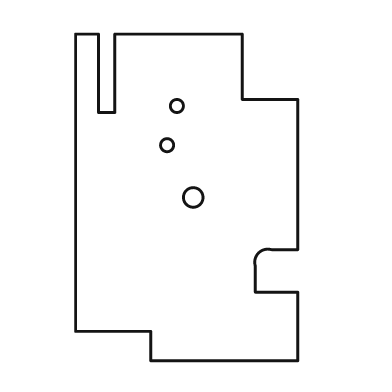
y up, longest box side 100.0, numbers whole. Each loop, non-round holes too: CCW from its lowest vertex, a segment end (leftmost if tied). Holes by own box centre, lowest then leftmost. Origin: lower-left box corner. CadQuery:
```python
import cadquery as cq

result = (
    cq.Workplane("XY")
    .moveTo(23.0, 0.0)
    .lineTo(68.0, 0.0)
    .lineTo(68.0, 21.0)
    .lineTo(55.0, 21.0)
    .lineTo(55.0, 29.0)
    .threePointArc((56.0, 33.0), (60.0, 34.0))
    .lineTo(68.0, 34.0)
    .lineTo(68.0, 80.0)
    .lineTo(51.0, 80.0)
    .lineTo(51.0, 100.0)
    .lineTo(12.0, 100.0)
    .lineTo(12.0, 76.0)
    .lineTo(7.0, 76.0)
    .lineTo(7.0, 100.0)
    .lineTo(0.0, 100.0)
    .lineTo(0.0, 9.0)
    .lineTo(23.0, 9.0)
    .close()
    .moveTo(36.0, 50.0)
    .circle(3.0)
    .moveTo(28.0, 66.0)
    .circle(2.0)
    .moveTo(31.0, 78.0)
    .circle(2.0)
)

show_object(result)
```